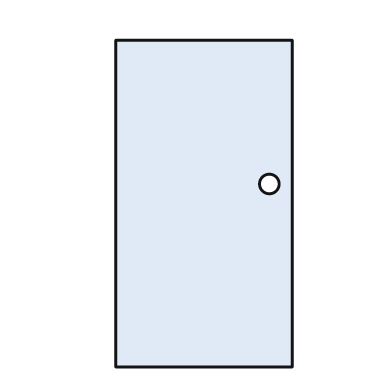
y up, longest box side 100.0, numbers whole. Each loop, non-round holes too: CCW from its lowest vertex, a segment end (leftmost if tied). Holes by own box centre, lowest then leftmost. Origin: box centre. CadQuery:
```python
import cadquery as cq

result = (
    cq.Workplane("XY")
    .moveTo(-27.0, -50.0)
    .lineTo(27.0, -50.0)
    .lineTo(27.0, 50.0)
    .lineTo(-27.0, 50.0)
    .close()
    .moveTo(20.0, 6.0)
    .circle(3.0)
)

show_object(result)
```